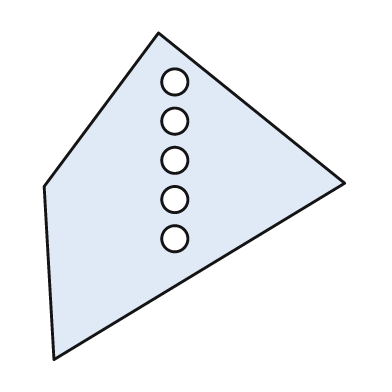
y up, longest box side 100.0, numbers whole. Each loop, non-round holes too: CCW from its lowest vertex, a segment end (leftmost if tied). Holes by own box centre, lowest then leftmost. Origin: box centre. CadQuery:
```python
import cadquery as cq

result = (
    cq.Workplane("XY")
    .moveTo(-43.0, -50.0)
    .lineTo(46.0, 4.0)
    .lineTo(-11.0, 50.0)
    .lineTo(-46.0, 3.0)
    .close()
    .moveTo(-6.0, -13.0)
    .circle(4.0)
    .moveTo(-6.0, -1.0)
    .circle(4.0)
    .moveTo(-6.0, 11.0)
    .circle(4.0)
    .moveTo(-6.0, 23.0)
    .circle(4.0)
    .moveTo(-6.0, 35.0)
    .circle(4.0)
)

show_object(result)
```